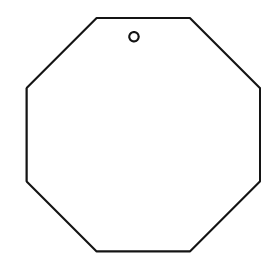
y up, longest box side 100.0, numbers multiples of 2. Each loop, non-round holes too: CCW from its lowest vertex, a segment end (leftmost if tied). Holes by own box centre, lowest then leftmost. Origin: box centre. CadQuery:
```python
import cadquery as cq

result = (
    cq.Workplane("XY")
    .moveTo(-20.0, -50.0)
    .lineTo(20.0, -50.0)
    .lineTo(50.0, -20.0)
    .lineTo(50.0, 20.0)
    .lineTo(20.0, 50.0)
    .lineTo(-20.0, 50.0)
    .lineTo(-50.0, 20.0)
    .lineTo(-50.0, -20.0)
    .close()
    .moveTo(-4.0, 42.0)
    .circle(2.0)
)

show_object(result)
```